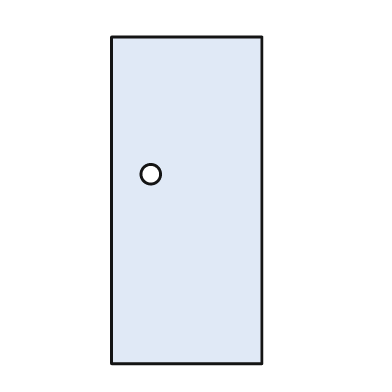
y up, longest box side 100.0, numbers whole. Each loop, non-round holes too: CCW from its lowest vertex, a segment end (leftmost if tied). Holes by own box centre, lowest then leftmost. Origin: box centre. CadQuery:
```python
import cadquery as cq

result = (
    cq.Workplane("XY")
    .moveTo(-23.0, -50.0)
    .lineTo(23.0, -50.0)
    .lineTo(23.0, 50.0)
    .lineTo(-23.0, 50.0)
    .close()
    .moveTo(-11.0, 8.0)
    .circle(3.0)
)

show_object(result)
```